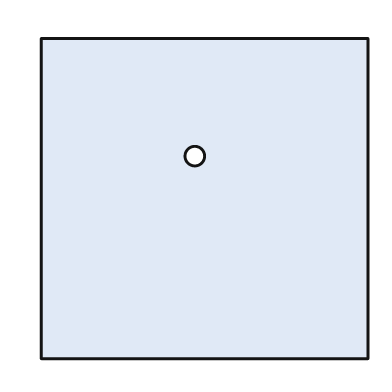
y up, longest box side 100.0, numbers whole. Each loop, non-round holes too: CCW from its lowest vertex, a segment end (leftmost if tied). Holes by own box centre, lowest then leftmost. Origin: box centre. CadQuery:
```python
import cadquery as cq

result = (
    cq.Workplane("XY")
    .moveTo(-50.0, -49.0)
    .lineTo(50.0, -49.0)
    .lineTo(50.0, 49.0)
    .lineTo(-50.0, 49.0)
    .close()
    .moveTo(-3.0, 13.0)
    .circle(3.0)
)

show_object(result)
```